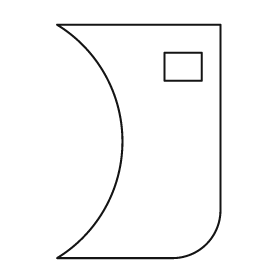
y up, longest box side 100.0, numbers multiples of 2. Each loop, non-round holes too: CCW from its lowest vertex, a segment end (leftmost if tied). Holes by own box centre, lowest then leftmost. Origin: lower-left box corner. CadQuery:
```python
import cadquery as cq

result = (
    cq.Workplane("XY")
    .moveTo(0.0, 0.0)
    .lineTo(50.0, 0.0)
    .threePointArc((64.0, 6.0), (70.0, 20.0))
    .lineTo(70.0, 100.0)
    .lineTo(0.0, 100.0)
    .threePointArc((28.0, 50.0), (0.0, 0.0))
    .close()
    .moveTo(46.0, 76.0)
    .lineTo(62.0, 76.0)
    .lineTo(62.0, 88.0)
    .lineTo(46.0, 88.0)
    .close()
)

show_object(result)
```